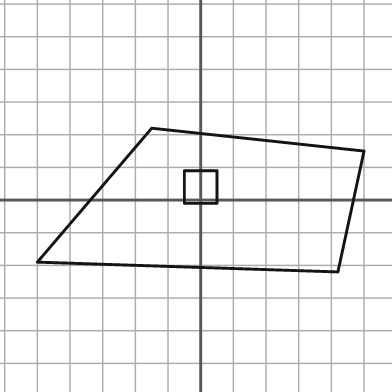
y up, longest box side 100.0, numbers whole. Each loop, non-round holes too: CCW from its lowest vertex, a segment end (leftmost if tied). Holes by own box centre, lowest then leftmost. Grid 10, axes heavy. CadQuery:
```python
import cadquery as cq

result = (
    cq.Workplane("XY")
    .moveTo(42.0, -22.0)
    .lineTo(50.0, 15.0)
    .lineTo(-15.0, 22.0)
    .lineTo(-50.0, -19.0)
    .close()
    .moveTo(-5.0, -1.0)
    .lineTo(5.0, -1.0)
    .lineTo(5.0, 9.0)
    .lineTo(-5.0, 9.0)
    .close()
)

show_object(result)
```